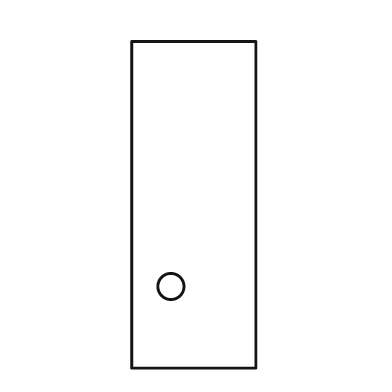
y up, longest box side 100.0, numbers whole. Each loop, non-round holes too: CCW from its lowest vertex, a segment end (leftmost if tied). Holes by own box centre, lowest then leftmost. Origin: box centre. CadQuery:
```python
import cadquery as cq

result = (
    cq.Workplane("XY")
    .moveTo(-19.0, -50.0)
    .lineTo(19.0, -50.0)
    .lineTo(19.0, 50.0)
    .lineTo(-19.0, 50.0)
    .close()
    .moveTo(-7.0, -25.0)
    .circle(4.0)
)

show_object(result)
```